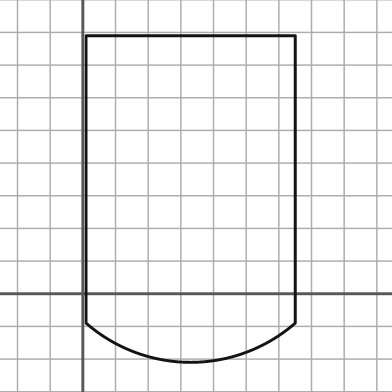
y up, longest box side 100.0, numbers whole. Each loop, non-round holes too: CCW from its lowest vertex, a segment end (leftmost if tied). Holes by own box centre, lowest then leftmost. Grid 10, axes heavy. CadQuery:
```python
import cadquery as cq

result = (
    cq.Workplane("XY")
    .moveTo(1.0, -9.0)
    .threePointArc((33.0, -21.0), (65.0, -9.0))
    .lineTo(65.0, 79.0)
    .lineTo(1.0, 79.0)
    .close()
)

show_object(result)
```